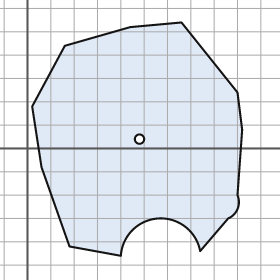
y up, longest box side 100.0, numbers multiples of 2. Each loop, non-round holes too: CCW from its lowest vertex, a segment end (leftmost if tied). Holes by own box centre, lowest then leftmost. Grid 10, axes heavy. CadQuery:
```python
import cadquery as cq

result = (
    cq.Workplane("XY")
    .moveTo(40.0, -46.0)
    .threePointArc((56.0, -30.0), (74.0, -44.0))
    .lineTo(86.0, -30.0)
    .threePointArc((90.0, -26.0), (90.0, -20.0))
    .lineTo(92.0, 8.0)
    .lineTo(90.0, 24.0)
    .lineTo(66.0, 54.0)
    .lineTo(44.0, 52.0)
    .lineTo(16.0, 44.0)
    .lineTo(2.0, 18.0)
    .lineTo(6.0, -8.0)
    .lineTo(18.0, -42.0)
    .close()
    .moveTo(48.0, 4.0)
    .circle(2.0)
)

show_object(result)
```